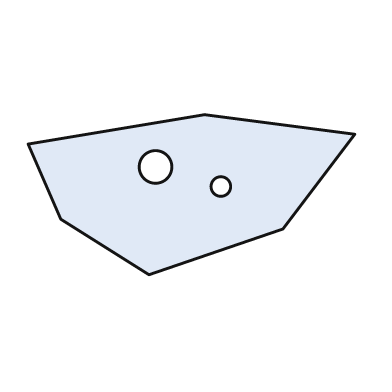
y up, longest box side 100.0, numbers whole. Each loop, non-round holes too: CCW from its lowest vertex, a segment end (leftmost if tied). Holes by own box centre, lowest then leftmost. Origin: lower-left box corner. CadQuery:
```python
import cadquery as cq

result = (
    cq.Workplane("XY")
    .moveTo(37.0, 0.0)
    .lineTo(78.0, 14.0)
    .lineTo(100.0, 43.0)
    .lineTo(54.0, 49.0)
    .lineTo(0.0, 40.0)
    .lineTo(10.0, 17.0)
    .close()
    .moveTo(59.0, 27.0)
    .circle(3.0)
    .moveTo(39.0, 33.0)
    .circle(5.0)
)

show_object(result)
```